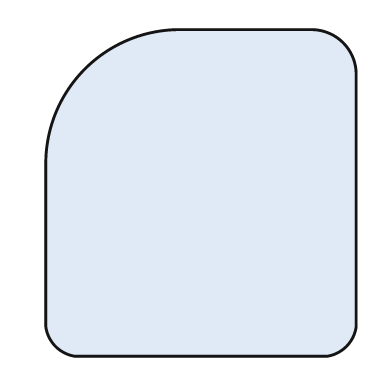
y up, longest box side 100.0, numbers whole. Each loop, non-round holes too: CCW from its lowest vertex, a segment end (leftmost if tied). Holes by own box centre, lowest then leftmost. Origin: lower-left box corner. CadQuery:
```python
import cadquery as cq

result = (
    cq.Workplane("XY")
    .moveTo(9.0, 0.0)
    .lineTo(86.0, 0.0)
    .threePointArc((92.0, 3.0), (95.0, 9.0))
    .lineTo(95.0, 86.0)
    .threePointArc((91.0, 96.0), (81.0, 100.0))
    .lineTo(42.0, 100.0)
    .threePointArc((12.0, 88.0), (0.0, 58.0))
    .lineTo(0.0, 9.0)
    .threePointArc((3.0, 3.0), (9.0, 0.0))
    .close()
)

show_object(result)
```